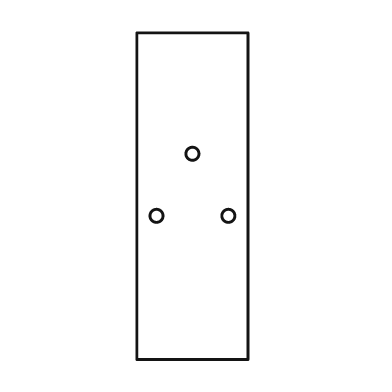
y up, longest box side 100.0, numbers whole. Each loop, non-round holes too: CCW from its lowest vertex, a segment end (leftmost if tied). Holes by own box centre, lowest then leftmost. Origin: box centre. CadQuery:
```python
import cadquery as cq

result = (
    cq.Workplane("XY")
    .moveTo(-17.0, -50.0)
    .lineTo(17.0, -50.0)
    .lineTo(17.0, 50.0)
    .lineTo(-17.0, 50.0)
    .close()
    .moveTo(-11.0, -6.0)
    .circle(2.0)
    .moveTo(11.0, -6.0)
    .circle(2.0)
    .moveTo(0.0, 13.0)
    .circle(2.0)
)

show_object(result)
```